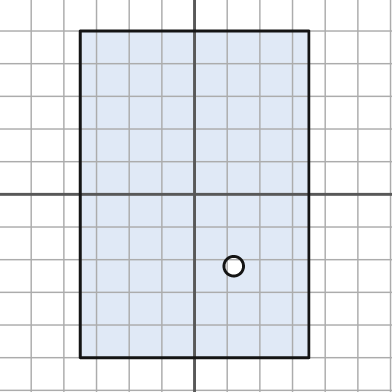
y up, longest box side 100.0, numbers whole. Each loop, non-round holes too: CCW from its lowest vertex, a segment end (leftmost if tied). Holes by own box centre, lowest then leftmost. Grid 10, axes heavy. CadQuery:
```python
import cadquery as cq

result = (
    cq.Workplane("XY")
    .moveTo(-35.0, -50.0)
    .lineTo(35.0, -50.0)
    .lineTo(35.0, 50.0)
    .lineTo(-35.0, 50.0)
    .close()
    .moveTo(12.0, -22.0)
    .circle(3.0)
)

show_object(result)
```